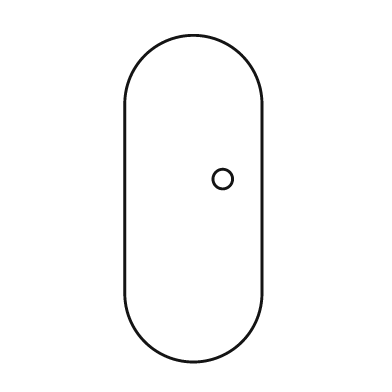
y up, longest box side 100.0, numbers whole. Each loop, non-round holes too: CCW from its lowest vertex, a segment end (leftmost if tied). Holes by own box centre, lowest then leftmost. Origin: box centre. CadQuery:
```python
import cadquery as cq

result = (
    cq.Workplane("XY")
    .moveTo(-21.0, -29.0)
    .threePointArc((0.0, -50.0), (21.0, -29.0))
    .lineTo(21.0, 29.0)
    .threePointArc((0.0, 50.0), (-21.0, 29.0))
    .close()
    .moveTo(9.0, 6.0)
    .circle(3.0)
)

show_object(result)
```